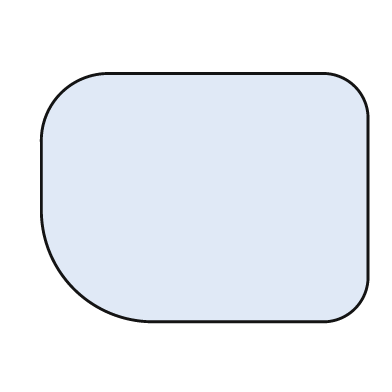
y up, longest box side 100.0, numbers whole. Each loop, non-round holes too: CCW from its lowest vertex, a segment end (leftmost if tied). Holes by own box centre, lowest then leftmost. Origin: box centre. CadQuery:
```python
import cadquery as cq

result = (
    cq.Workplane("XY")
    .moveTo(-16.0, -38.0)
    .lineTo(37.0, -38.0)
    .threePointArc((46.0, -34.0), (50.0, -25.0))
    .lineTo(50.0, 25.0)
    .threePointArc((46.0, 34.0), (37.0, 38.0))
    .lineTo(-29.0, 38.0)
    .threePointArc((-44.0, 32.0), (-50.0, 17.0))
    .lineTo(-50.0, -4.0)
    .threePointArc((-40.0, -28.0), (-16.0, -38.0))
    .close()
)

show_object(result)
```